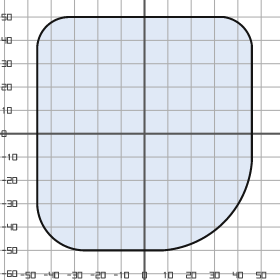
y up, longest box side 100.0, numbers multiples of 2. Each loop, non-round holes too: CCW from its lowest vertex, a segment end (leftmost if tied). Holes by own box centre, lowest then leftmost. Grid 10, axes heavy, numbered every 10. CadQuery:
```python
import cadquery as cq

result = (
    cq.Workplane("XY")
    .moveTo(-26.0, -50.0)
    .lineTo(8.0, -50.0)
    .threePointArc((34.0, -38.0), (46.0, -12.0))
    .lineTo(46.0, 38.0)
    .threePointArc((42.0, 46.0), (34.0, 50.0))
    .lineTo(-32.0, 50.0)
    .threePointArc((-42.0, 46.0), (-46.0, 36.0))
    .lineTo(-46.0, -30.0)
    .threePointArc((-40.0, -44.0), (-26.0, -50.0))
    .close()
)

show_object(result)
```